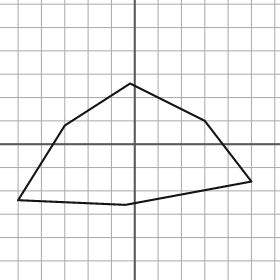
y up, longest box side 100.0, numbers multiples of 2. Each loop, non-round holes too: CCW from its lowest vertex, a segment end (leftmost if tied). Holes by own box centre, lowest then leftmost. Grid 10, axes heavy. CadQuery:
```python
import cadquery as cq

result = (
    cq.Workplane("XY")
    .moveTo(-4.0, -26.0)
    .lineTo(50.0, -16.0)
    .lineTo(30.0, 10.0)
    .lineTo(-2.0, 26.0)
    .lineTo(-30.0, 8.0)
    .lineTo(-50.0, -24.0)
    .close()
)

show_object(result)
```